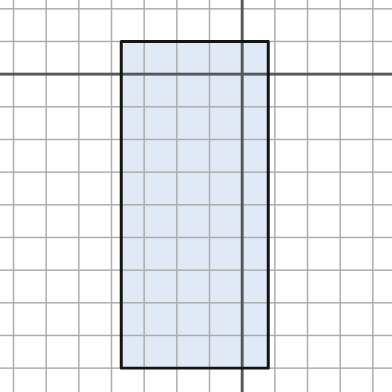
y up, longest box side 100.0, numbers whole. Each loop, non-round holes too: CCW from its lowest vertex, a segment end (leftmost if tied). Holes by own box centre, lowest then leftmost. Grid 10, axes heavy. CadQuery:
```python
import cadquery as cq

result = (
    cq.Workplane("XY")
    .moveTo(-37.0, -90.0)
    .lineTo(8.0, -90.0)
    .lineTo(8.0, 10.0)
    .lineTo(-37.0, 10.0)
    .close()
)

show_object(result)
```